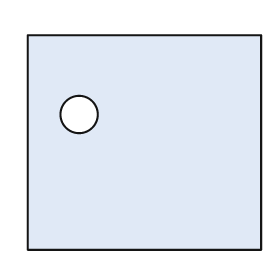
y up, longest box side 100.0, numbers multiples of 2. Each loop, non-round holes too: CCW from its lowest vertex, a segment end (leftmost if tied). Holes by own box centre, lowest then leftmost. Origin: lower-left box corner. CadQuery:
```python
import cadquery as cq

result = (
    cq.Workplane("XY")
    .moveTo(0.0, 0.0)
    .lineTo(100.0, 0.0)
    .lineTo(100.0, 92.0)
    .lineTo(0.0, 92.0)
    .close()
    .moveTo(22.0, 58.0)
    .circle(8.0)
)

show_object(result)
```